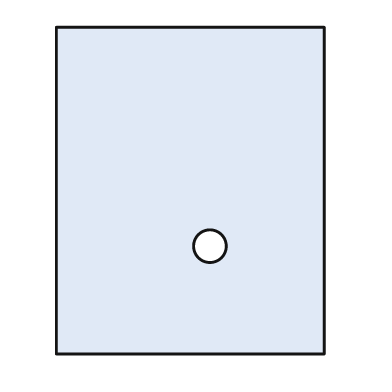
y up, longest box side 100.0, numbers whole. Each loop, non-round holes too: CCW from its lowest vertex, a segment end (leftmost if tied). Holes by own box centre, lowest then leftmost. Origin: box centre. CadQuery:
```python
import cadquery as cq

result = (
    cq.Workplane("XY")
    .moveTo(-41.0, -50.0)
    .lineTo(41.0, -50.0)
    .lineTo(41.0, 50.0)
    .lineTo(-41.0, 50.0)
    .close()
    .moveTo(6.0, -17.0)
    .circle(5.0)
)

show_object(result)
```